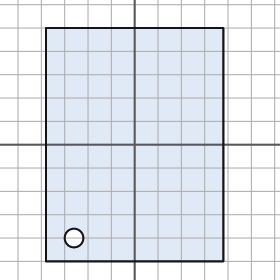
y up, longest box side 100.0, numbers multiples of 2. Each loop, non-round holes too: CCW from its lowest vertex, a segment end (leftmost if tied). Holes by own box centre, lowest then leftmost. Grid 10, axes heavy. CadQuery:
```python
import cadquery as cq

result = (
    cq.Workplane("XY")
    .moveTo(-38.0, -50.0)
    .lineTo(38.0, -50.0)
    .lineTo(38.0, 50.0)
    .lineTo(-38.0, 50.0)
    .close()
    .moveTo(-26.0, -40.0)
    .circle(4.0)
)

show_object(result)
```